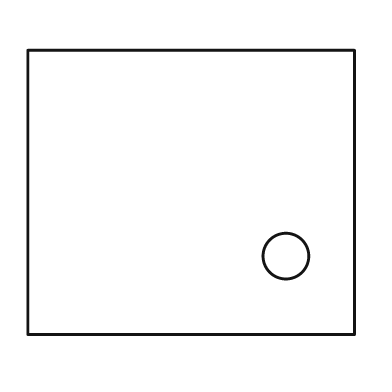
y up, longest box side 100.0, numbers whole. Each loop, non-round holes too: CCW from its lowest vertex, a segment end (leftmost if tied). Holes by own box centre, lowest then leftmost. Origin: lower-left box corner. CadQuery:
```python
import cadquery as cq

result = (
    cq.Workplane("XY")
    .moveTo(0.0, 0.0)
    .lineTo(100.0, 0.0)
    .lineTo(100.0, 87.0)
    .lineTo(0.0, 87.0)
    .close()
    .moveTo(79.0, 24.0)
    .circle(7.0)
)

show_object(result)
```